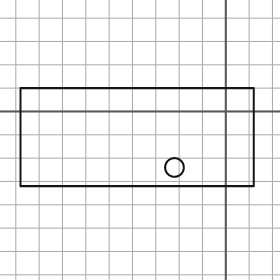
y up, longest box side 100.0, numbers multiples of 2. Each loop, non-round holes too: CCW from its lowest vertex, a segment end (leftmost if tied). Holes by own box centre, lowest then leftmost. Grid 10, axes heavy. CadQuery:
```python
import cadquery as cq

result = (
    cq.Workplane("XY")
    .moveTo(-88.0, -32.0)
    .lineTo(12.0, -32.0)
    .lineTo(12.0, 10.0)
    .lineTo(-88.0, 10.0)
    .close()
    .moveTo(-22.0, -24.0)
    .circle(4.0)
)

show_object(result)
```